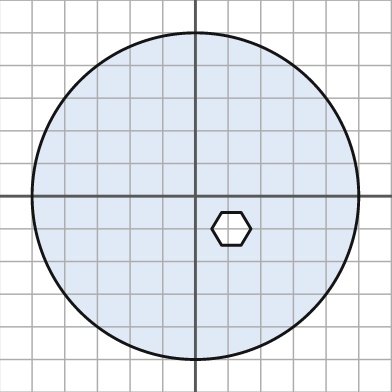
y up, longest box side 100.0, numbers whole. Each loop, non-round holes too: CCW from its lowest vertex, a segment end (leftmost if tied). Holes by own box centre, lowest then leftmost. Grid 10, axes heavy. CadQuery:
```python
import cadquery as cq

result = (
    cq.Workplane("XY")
    .moveTo(0.0, 0.0)
    .circle(50.0)
    .moveTo(8.0, -15.0)
    .lineTo(14.0, -15.0)
    .lineTo(17.0, -10.0)
    .lineTo(14.0, -5.0)
    .lineTo(8.0, -5.0)
    .lineTo(5.0, -10.0)
    .close()
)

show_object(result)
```